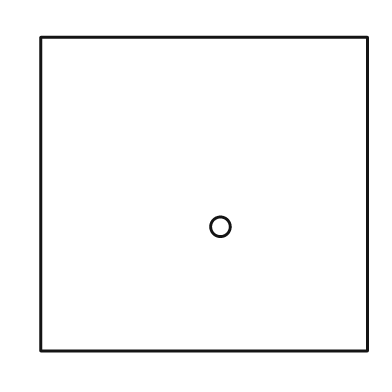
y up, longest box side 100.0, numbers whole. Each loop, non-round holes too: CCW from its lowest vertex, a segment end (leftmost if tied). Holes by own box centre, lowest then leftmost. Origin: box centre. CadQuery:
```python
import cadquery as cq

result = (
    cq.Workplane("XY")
    .moveTo(-50.0, -48.0)
    .lineTo(50.0, -48.0)
    .lineTo(50.0, 48.0)
    .lineTo(-50.0, 48.0)
    .close()
    .moveTo(5.0, -10.0)
    .circle(3.0)
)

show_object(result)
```